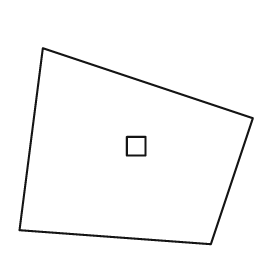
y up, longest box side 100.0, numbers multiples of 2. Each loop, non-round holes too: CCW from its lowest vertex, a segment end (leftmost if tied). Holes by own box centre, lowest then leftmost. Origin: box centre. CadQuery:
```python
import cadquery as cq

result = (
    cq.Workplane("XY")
    .moveTo(32.0, -42.0)
    .lineTo(50.0, 12.0)
    .lineTo(-40.0, 42.0)
    .lineTo(-50.0, -36.0)
    .close()
    .moveTo(-4.0, -4.0)
    .lineTo(4.0, -4.0)
    .lineTo(4.0, 4.0)
    .lineTo(-4.0, 4.0)
    .close()
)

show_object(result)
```